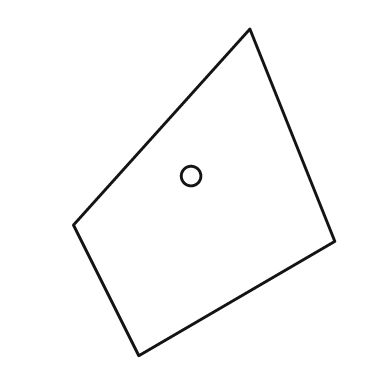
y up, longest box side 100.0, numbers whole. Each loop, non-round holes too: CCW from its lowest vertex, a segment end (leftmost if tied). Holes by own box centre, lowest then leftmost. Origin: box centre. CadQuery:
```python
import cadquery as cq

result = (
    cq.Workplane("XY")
    .moveTo(-20.0, -50.0)
    .lineTo(40.0, -15.0)
    .lineTo(14.0, 50.0)
    .lineTo(-40.0, -10.0)
    .close()
    .moveTo(-4.0, 5.0)
    .circle(3.0)
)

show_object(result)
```